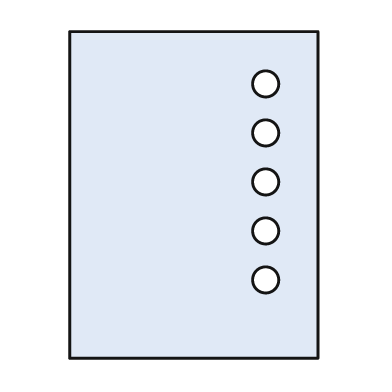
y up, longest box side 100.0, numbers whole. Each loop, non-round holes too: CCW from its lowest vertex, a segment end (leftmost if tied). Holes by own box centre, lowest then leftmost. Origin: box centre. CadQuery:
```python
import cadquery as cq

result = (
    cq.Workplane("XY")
    .moveTo(-38.0, -50.0)
    .lineTo(38.0, -50.0)
    .lineTo(38.0, 50.0)
    .lineTo(-38.0, 50.0)
    .close()
    .moveTo(22.0, -26.0)
    .circle(4.0)
    .moveTo(22.0, -11.0)
    .circle(4.0)
    .moveTo(22.0, 4.0)
    .circle(4.0)
    .moveTo(22.0, 19.0)
    .circle(4.0)
    .moveTo(22.0, 34.0)
    .circle(4.0)
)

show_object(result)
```